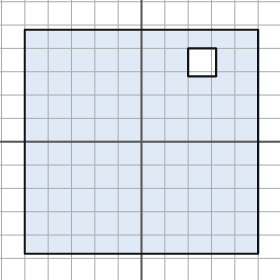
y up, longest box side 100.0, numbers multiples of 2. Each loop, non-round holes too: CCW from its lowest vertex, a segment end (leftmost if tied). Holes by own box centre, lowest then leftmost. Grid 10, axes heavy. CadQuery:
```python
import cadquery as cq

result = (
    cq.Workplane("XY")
    .moveTo(-50.0, -48.0)
    .lineTo(50.0, -48.0)
    .lineTo(50.0, 48.0)
    .lineTo(-50.0, 48.0)
    .close()
    .moveTo(20.0, 28.0)
    .lineTo(32.0, 28.0)
    .lineTo(32.0, 40.0)
    .lineTo(20.0, 40.0)
    .close()
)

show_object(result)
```